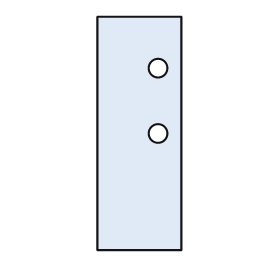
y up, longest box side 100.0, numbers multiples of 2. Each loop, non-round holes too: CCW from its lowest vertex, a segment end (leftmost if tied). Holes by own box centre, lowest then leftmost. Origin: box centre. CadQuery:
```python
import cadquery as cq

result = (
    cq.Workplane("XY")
    .moveTo(-18.0, -50.0)
    .lineTo(18.0, -50.0)
    .lineTo(18.0, 50.0)
    .lineTo(-18.0, 50.0)
    .close()
    .moveTo(8.0, 0.0)
    .circle(4.0)
    .moveTo(8.0, 28.0)
    .circle(4.0)
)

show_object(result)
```